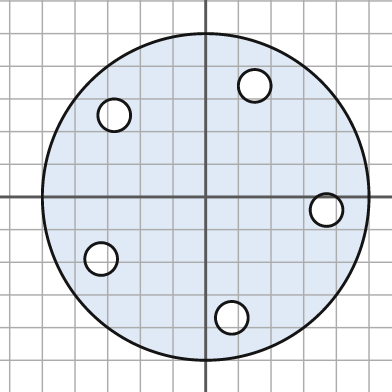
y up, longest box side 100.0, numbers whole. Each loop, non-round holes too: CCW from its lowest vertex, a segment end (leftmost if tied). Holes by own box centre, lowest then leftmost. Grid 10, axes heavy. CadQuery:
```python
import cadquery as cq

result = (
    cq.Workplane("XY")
    .moveTo(0.0, 0.0)
    .circle(50.0)
    .moveTo(8.0, -37.0)
    .circle(5.0)
    .moveTo(-32.0, -19.0)
    .circle(5.0)
    .moveTo(37.0, -4.0)
    .circle(5.0)
    .moveTo(-28.0, 25.0)
    .circle(5.0)
    .moveTo(15.0, 34.0)
    .circle(5.0)
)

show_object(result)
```